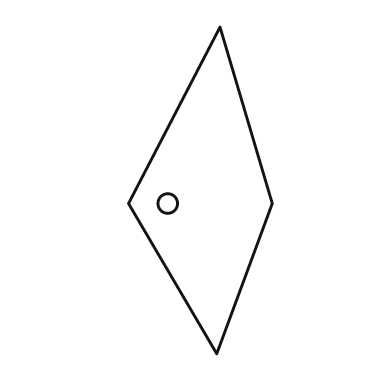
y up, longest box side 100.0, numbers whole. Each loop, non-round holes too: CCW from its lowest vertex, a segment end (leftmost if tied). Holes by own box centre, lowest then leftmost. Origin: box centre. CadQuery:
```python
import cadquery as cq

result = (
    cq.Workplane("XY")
    .moveTo(5.0, -50.0)
    .lineTo(22.0, -4.0)
    .lineTo(6.0, 50.0)
    .lineTo(-22.0, -4.0)
    .close()
    .moveTo(-10.0, -4.0)
    .circle(3.0)
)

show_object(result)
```